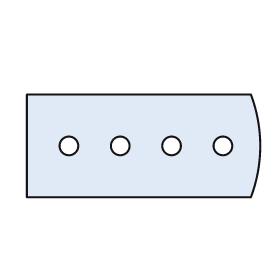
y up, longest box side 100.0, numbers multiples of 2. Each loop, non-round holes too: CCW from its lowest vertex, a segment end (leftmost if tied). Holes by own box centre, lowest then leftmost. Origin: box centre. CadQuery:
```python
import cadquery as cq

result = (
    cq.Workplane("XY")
    .moveTo(-50.0, -22.0)
    .lineTo(46.0, -22.0)
    .threePointArc((50.0, 0.0), (46.0, 22.0))
    .lineTo(-50.0, 22.0)
    .close()
    .moveTo(-32.0, 0.0)
    .circle(4.0)
    .moveTo(-10.0, 0.0)
    .circle(4.0)
    .moveTo(12.0, 0.0)
    .circle(4.0)
    .moveTo(34.0, 0.0)
    .circle(4.0)
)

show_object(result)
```